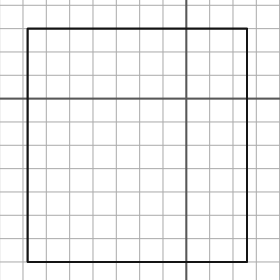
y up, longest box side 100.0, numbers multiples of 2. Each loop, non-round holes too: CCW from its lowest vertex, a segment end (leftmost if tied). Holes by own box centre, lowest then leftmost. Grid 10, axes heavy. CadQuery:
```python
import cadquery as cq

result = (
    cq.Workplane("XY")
    .moveTo(-68.0, -70.0)
    .lineTo(26.0, -70.0)
    .lineTo(26.0, 30.0)
    .lineTo(-68.0, 30.0)
    .close()
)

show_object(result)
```